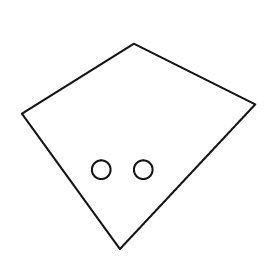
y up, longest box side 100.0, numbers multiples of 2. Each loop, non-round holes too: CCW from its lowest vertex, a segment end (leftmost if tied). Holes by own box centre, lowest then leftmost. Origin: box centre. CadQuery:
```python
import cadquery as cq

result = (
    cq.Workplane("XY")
    .moveTo(-8.0, -44.0)
    .lineTo(50.0, 18.0)
    .lineTo(-2.0, 44.0)
    .lineTo(-50.0, 14.0)
    .close()
    .moveTo(-16.0, -10.0)
    .circle(4.0)
    .moveTo(2.0, -10.0)
    .circle(4.0)
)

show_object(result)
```